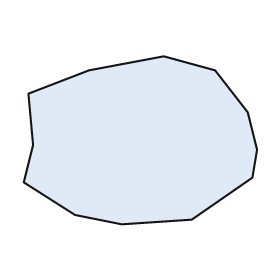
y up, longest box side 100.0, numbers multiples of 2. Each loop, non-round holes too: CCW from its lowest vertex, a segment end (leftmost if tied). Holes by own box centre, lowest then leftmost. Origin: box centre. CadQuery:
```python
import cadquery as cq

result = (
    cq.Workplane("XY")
    .moveTo(-8.0, -36.0)
    .lineTo(22.0, -34.0)
    .lineTo(48.0, -16.0)
    .lineTo(50.0, -4.0)
    .lineTo(46.0, 12.0)
    .lineTo(32.0, 30.0)
    .lineTo(10.0, 36.0)
    .lineTo(-22.0, 30.0)
    .lineTo(-48.0, 20.0)
    .lineTo(-46.0, -2.0)
    .lineTo(-50.0, -18.0)
    .lineTo(-28.0, -32.0)
    .close()
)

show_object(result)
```